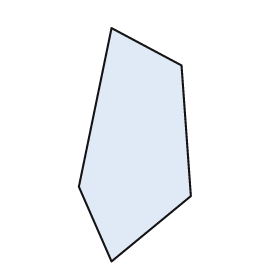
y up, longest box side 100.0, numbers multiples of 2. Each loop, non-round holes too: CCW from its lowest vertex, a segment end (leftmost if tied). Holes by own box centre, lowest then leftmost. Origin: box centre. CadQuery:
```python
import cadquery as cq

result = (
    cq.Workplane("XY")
    .moveTo(-10.0, -50.0)
    .lineTo(24.0, -22.0)
    .lineTo(20.0, 34.0)
    .lineTo(-10.0, 50.0)
    .lineTo(-24.0, -18.0)
    .close()
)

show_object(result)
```